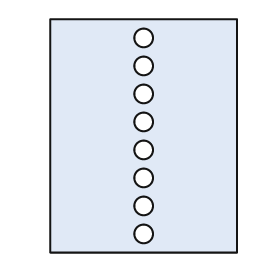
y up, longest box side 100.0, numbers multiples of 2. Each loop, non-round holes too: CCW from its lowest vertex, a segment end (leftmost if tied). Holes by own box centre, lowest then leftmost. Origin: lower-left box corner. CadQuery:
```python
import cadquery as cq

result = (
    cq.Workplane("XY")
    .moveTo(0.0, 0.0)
    .lineTo(80.0, 0.0)
    .lineTo(80.0, 100.0)
    .lineTo(0.0, 100.0)
    .close()
    .moveTo(40.0, 8.0)
    .circle(4.0)
    .moveTo(40.0, 20.0)
    .circle(4.0)
    .moveTo(40.0, 32.0)
    .circle(4.0)
    .moveTo(40.0, 44.0)
    .circle(4.0)
    .moveTo(40.0, 56.0)
    .circle(4.0)
    .moveTo(40.0, 68.0)
    .circle(4.0)
    .moveTo(40.0, 80.0)
    .circle(4.0)
    .moveTo(40.0, 92.0)
    .circle(4.0)
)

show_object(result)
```